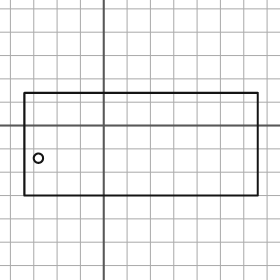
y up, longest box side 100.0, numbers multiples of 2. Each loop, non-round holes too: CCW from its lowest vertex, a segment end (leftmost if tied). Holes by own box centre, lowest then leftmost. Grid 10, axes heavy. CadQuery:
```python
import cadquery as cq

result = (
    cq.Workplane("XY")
    .moveTo(-34.0, -30.0)
    .lineTo(66.0, -30.0)
    .lineTo(66.0, 14.0)
    .lineTo(-34.0, 14.0)
    .close()
    .moveTo(-28.0, -14.0)
    .circle(2.0)
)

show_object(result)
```